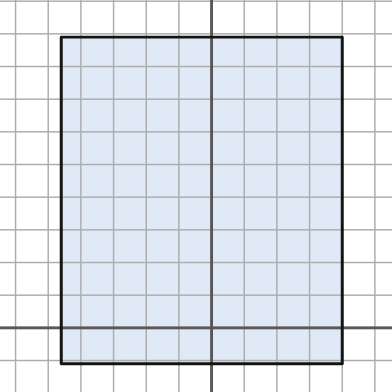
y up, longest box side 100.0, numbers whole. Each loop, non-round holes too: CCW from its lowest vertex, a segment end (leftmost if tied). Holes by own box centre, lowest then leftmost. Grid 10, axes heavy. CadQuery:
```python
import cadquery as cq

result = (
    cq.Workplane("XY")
    .moveTo(-46.0, -11.0)
    .lineTo(40.0, -11.0)
    .lineTo(40.0, 89.0)
    .lineTo(-46.0, 89.0)
    .close()
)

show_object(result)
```